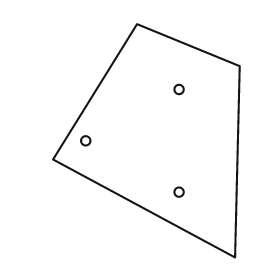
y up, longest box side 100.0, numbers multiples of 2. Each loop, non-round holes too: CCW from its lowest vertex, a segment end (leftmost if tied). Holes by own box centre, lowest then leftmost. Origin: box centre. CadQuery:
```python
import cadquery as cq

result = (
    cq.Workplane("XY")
    .moveTo(38.0, -50.0)
    .lineTo(40.0, 32.0)
    .lineTo(-4.0, 50.0)
    .lineTo(-40.0, -8.0)
    .close()
    .moveTo(14.0, -22.0)
    .circle(2.0)
    .moveTo(-26.0, 0.0)
    .circle(2.0)
    .moveTo(14.0, 22.0)
    .circle(2.0)
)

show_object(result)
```